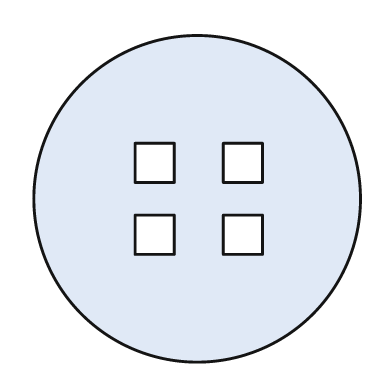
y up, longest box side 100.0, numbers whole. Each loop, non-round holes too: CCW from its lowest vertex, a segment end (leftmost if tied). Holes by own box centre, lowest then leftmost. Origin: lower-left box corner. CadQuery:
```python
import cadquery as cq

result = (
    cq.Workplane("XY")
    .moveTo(50.0, 50.0)
    .circle(50.0)
    .moveTo(31.0, 33.0)
    .lineTo(43.0, 33.0)
    .lineTo(43.0, 45.0)
    .lineTo(31.0, 45.0)
    .close()
    .moveTo(58.0, 33.0)
    .lineTo(70.0, 33.0)
    .lineTo(70.0, 45.0)
    .lineTo(58.0, 45.0)
    .close()
    .moveTo(31.0, 55.0)
    .lineTo(43.0, 55.0)
    .lineTo(43.0, 67.0)
    .lineTo(31.0, 67.0)
    .close()
    .moveTo(58.0, 55.0)
    .lineTo(70.0, 55.0)
    .lineTo(70.0, 67.0)
    .lineTo(58.0, 67.0)
    .close()
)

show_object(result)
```